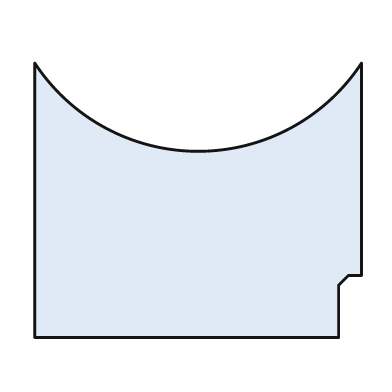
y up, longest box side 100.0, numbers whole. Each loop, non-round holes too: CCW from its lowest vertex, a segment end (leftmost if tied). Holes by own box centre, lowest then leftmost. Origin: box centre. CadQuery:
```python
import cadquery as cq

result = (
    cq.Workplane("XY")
    .moveTo(-50.0, -42.0)
    .lineTo(43.0, -42.0)
    .lineTo(43.0, -26.0)
    .lineTo(46.0, -23.0)
    .lineTo(50.0, -23.0)
    .lineTo(50.0, 42.0)
    .threePointArc((0.0, 15.0), (-50.0, 42.0))
    .close()
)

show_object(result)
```